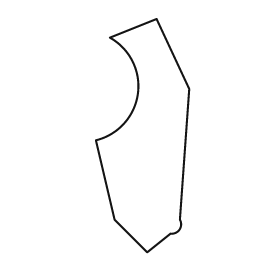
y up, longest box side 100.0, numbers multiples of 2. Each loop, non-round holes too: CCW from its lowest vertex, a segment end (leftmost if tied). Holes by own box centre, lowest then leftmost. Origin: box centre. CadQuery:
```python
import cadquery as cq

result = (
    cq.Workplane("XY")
    .moveTo(2.0, -50.0)
    .lineTo(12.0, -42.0)
    .threePointArc((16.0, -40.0), (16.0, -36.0))
    .lineTo(20.0, 20.0)
    .lineTo(6.0, 50.0)
    .lineTo(-14.0, 42.0)
    .threePointArc((-2.0, 18.0), (-20.0, -2.0))
    .lineTo(-12.0, -36.0)
    .close()
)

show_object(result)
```